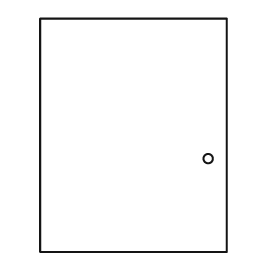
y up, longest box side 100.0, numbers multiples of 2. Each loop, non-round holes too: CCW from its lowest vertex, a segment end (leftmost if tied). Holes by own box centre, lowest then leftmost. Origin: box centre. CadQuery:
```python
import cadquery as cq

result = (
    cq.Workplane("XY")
    .moveTo(-40.0, -50.0)
    .lineTo(40.0, -50.0)
    .lineTo(40.0, 50.0)
    .lineTo(-40.0, 50.0)
    .close()
    .moveTo(32.0, -10.0)
    .circle(2.0)
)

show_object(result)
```